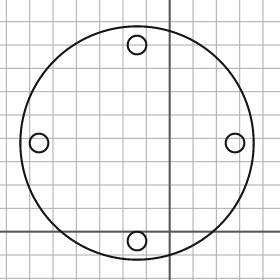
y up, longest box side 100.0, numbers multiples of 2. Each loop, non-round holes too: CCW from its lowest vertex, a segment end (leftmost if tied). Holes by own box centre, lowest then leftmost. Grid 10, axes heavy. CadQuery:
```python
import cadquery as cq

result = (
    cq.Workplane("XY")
    .moveTo(-14.0, 38.0)
    .circle(50.0)
    .moveTo(-14.0, -4.0)
    .circle(4.0)
    .moveTo(-56.0, 38.0)
    .circle(4.0)
    .moveTo(28.0, 38.0)
    .circle(4.0)
    .moveTo(-14.0, 80.0)
    .circle(4.0)
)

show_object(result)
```